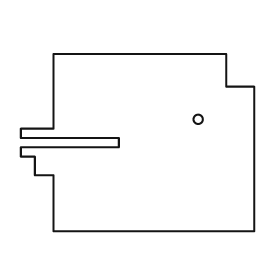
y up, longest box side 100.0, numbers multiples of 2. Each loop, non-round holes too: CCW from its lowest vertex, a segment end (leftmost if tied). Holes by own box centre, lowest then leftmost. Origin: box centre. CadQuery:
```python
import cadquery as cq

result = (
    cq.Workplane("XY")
    .moveTo(-36.0, -38.0)
    .lineTo(50.0, -38.0)
    .lineTo(50.0, 24.0)
    .lineTo(38.0, 24.0)
    .lineTo(38.0, 38.0)
    .lineTo(-36.0, 38.0)
    .lineTo(-36.0, 6.0)
    .lineTo(-50.0, 6.0)
    .lineTo(-50.0, 2.0)
    .lineTo(-8.0, 2.0)
    .lineTo(-8.0, -2.0)
    .lineTo(-50.0, -2.0)
    .lineTo(-50.0, -6.0)
    .lineTo(-44.0, -6.0)
    .lineTo(-44.0, -14.0)
    .lineTo(-36.0, -14.0)
    .close()
    .moveTo(26.0, 10.0)
    .circle(2.0)
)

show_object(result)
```